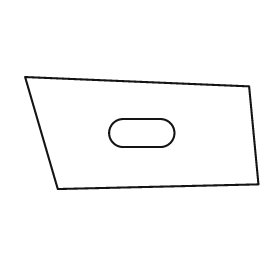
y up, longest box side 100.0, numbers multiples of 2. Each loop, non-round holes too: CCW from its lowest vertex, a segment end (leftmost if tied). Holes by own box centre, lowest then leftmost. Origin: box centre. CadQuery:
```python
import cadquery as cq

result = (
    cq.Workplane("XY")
    .moveTo(-36.0, -24.0)
    .lineTo(50.0, -22.0)
    .lineTo(46.0, 20.0)
    .lineTo(-50.0, 24.0)
    .close()
    .moveTo(-8.0, -6.0)
    .lineTo(8.0, -6.0)
    .threePointArc((14.0, 0.0), (8.0, 6.0))
    .lineTo(-8.0, 6.0)
    .threePointArc((-14.0, 0.0), (-8.0, -6.0))
    .close()
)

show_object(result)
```